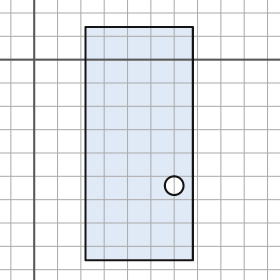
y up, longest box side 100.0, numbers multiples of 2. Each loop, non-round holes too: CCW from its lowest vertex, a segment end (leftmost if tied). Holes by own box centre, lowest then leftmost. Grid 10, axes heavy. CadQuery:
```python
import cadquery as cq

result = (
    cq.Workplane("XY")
    .moveTo(22.0, -86.0)
    .lineTo(68.0, -86.0)
    .lineTo(68.0, 14.0)
    .lineTo(22.0, 14.0)
    .close()
    .moveTo(60.0, -54.0)
    .circle(4.0)
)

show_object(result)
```